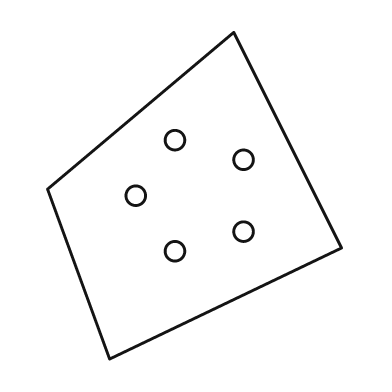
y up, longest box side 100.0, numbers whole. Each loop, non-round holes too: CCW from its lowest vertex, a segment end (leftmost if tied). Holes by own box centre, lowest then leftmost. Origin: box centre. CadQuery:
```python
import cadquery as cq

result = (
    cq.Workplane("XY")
    .moveTo(-26.0, -50.0)
    .lineTo(45.0, -16.0)
    .lineTo(12.0, 50.0)
    .lineTo(-45.0, 2.0)
    .close()
    .moveTo(-6.0, -17.0)
    .circle(3.0)
    .moveTo(15.0, -11.0)
    .circle(3.0)
    .moveTo(-18.0, 0.0)
    .circle(3.0)
    .moveTo(15.0, 11.0)
    .circle(3.0)
    .moveTo(-6.0, 17.0)
    .circle(3.0)
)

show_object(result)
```